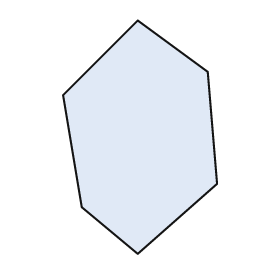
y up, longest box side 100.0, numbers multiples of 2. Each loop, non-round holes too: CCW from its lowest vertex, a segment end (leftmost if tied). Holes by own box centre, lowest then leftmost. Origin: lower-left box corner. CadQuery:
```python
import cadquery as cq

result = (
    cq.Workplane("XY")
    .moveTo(32.0, 0.0)
    .lineTo(66.0, 30.0)
    .lineTo(62.0, 78.0)
    .lineTo(32.0, 100.0)
    .lineTo(0.0, 68.0)
    .lineTo(8.0, 20.0)
    .close()
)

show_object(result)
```